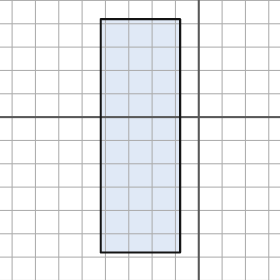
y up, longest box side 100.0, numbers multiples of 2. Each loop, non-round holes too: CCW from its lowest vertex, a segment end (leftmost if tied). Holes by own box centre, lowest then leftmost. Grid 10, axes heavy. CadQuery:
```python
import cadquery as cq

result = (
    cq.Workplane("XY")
    .moveTo(-42.0, -58.0)
    .lineTo(-8.0, -58.0)
    .lineTo(-8.0, 42.0)
    .lineTo(-42.0, 42.0)
    .close()
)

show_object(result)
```